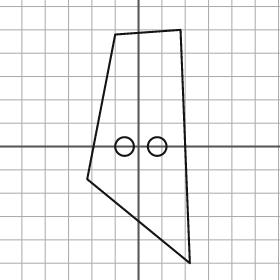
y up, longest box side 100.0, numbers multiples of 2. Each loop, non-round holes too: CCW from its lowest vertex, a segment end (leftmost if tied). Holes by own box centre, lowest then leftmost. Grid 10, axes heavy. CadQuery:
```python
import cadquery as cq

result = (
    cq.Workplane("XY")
    .moveTo(22.0, -50.0)
    .lineTo(18.0, 50.0)
    .lineTo(-10.0, 48.0)
    .lineTo(-22.0, -14.0)
    .close()
    .moveTo(-6.0, 0.0)
    .circle(4.0)
    .moveTo(8.0, 0.0)
    .circle(4.0)
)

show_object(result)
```